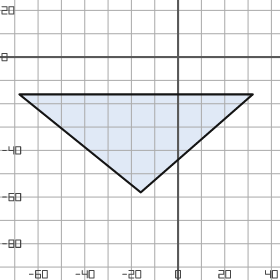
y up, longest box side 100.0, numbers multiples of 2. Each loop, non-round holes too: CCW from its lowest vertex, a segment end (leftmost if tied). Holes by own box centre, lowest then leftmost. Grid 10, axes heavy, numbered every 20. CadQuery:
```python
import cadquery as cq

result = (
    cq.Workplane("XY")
    .moveTo(-16.0, -58.0)
    .lineTo(32.0, -16.0)
    .lineTo(-68.0, -16.0)
    .close()
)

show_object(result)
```